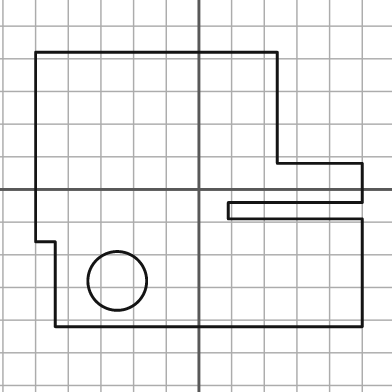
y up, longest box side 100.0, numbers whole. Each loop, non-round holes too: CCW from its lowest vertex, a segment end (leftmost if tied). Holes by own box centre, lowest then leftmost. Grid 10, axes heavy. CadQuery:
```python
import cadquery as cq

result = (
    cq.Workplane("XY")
    .moveTo(-44.0, -42.0)
    .lineTo(50.0, -42.0)
    .lineTo(50.0, -9.0)
    .lineTo(9.0, -9.0)
    .lineTo(9.0, -4.0)
    .lineTo(50.0, -4.0)
    .lineTo(50.0, 8.0)
    .lineTo(24.0, 8.0)
    .lineTo(24.0, 42.0)
    .lineTo(-50.0, 42.0)
    .lineTo(-50.0, -16.0)
    .lineTo(-44.0, -16.0)
    .close()
    .moveTo(-25.0, -28.0)
    .circle(9.0)
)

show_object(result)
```